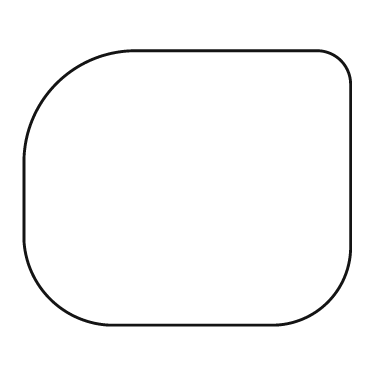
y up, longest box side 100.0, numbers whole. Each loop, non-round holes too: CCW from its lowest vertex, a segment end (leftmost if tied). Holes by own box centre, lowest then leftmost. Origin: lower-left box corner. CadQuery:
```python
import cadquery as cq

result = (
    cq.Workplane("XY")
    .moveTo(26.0, 0.0)
    .lineTo(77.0, 0.0)
    .threePointArc((93.0, 7.0), (100.0, 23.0))
    .lineTo(100.0, 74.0)
    .threePointArc((97.0, 81.0), (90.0, 84.0))
    .lineTo(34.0, 84.0)
    .threePointArc((10.0, 74.0), (0.0, 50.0))
    .lineTo(0.0, 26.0)
    .threePointArc((8.0, 8.0), (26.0, 0.0))
    .close()
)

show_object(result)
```